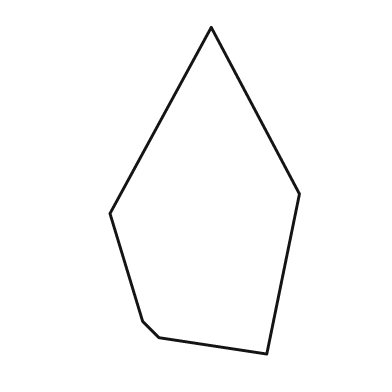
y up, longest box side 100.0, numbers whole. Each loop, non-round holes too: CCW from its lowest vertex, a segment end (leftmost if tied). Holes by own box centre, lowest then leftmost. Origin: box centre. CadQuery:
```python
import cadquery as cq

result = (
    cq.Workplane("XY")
    .moveTo(19.0, -50.0)
    .lineTo(29.0, -1.0)
    .lineTo(2.0, 50.0)
    .lineTo(-29.0, -7.0)
    .lineTo(-19.0, -40.0)
    .lineTo(-14.0, -45.0)
    .close()
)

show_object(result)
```